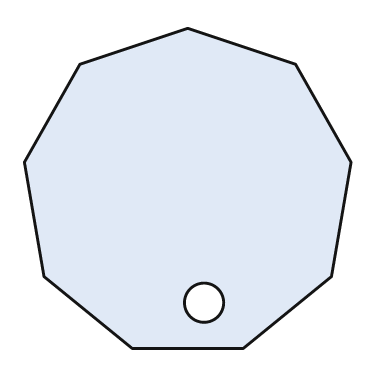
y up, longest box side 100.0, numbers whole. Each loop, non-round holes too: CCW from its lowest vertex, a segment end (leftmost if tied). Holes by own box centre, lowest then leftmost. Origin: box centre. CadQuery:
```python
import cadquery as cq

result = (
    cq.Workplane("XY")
    .moveTo(-17.0, -49.0)
    .lineTo(17.0, -49.0)
    .lineTo(44.0, -27.0)
    .lineTo(50.0, 8.0)
    .lineTo(33.0, 38.0)
    .lineTo(0.0, 49.0)
    .lineTo(-33.0, 38.0)
    .lineTo(-50.0, 8.0)
    .lineTo(-44.0, -27.0)
    .close()
    .moveTo(5.0, -35.0)
    .circle(6.0)
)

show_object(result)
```